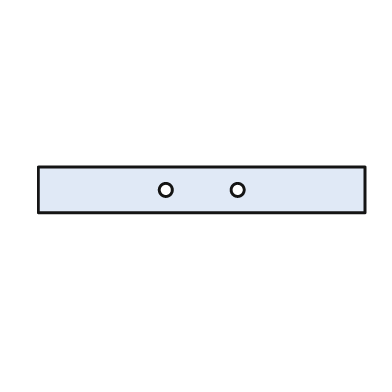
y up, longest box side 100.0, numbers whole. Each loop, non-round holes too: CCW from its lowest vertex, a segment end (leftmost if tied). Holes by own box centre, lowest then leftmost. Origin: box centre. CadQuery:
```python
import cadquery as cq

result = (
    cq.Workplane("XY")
    .moveTo(-50.0, -7.0)
    .lineTo(50.0, -7.0)
    .lineTo(50.0, 7.0)
    .lineTo(-50.0, 7.0)
    .close()
    .moveTo(-11.0, 0.0)
    .circle(2.0)
    .moveTo(11.0, 0.0)
    .circle(2.0)
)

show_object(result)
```